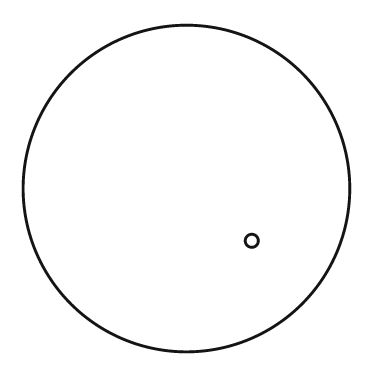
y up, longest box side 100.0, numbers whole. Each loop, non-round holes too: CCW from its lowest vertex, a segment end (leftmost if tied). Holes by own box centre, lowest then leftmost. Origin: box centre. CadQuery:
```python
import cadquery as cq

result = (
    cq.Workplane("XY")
    .moveTo(0.0, 0.0)
    .circle(50.0)
    .moveTo(20.0, -16.0)
    .circle(2.0)
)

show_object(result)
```